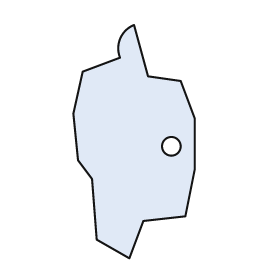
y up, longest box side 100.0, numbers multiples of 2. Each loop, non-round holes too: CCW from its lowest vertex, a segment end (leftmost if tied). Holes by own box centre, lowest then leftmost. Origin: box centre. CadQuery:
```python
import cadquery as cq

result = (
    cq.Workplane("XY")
    .moveTo(-2.0, -50.0)
    .lineTo(4.0, -34.0)
    .lineTo(22.0, -32.0)
    .lineTo(26.0, -12.0)
    .lineTo(26.0, 10.0)
    .lineTo(20.0, 26.0)
    .lineTo(6.0, 28.0)
    .lineTo(0.0, 50.0)
    .threePointArc((-6.0, 44.0), (-6.0, 36.0))
    .lineTo(-22.0, 30.0)
    .lineTo(-26.0, 12.0)
    .lineTo(-24.0, -8.0)
    .lineTo(-18.0, -16.0)
    .lineTo(-16.0, -42.0)
    .close()
    .moveTo(16.0, -2.0)
    .circle(4.0)
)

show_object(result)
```